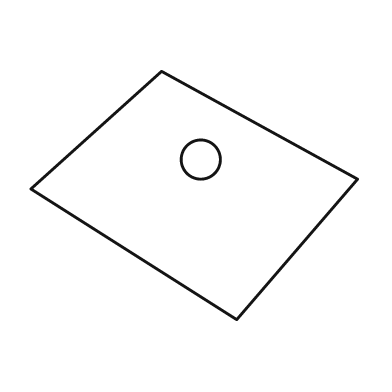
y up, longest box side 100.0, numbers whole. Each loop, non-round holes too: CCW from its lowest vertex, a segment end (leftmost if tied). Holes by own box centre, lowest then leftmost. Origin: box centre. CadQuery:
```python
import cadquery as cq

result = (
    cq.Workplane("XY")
    .moveTo(13.0, -38.0)
    .lineTo(50.0, 5.0)
    .lineTo(-10.0, 38.0)
    .lineTo(-50.0, 2.0)
    .close()
    .moveTo(2.0, 11.0)
    .circle(6.0)
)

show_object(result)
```